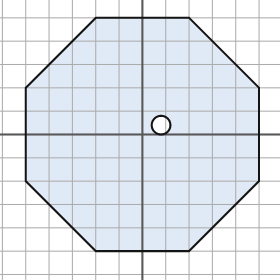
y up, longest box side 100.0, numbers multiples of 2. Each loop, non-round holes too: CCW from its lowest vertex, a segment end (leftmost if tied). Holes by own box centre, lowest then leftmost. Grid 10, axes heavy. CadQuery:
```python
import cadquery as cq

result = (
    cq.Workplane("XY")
    .moveTo(-20.0, -50.0)
    .lineTo(20.0, -50.0)
    .lineTo(50.0, -20.0)
    .lineTo(50.0, 20.0)
    .lineTo(20.0, 50.0)
    .lineTo(-20.0, 50.0)
    .lineTo(-50.0, 20.0)
    .lineTo(-50.0, -20.0)
    .close()
    .moveTo(8.0, 4.0)
    .circle(4.0)
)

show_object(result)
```